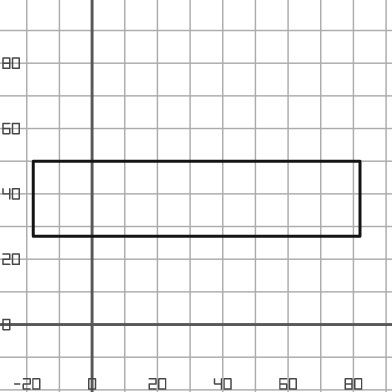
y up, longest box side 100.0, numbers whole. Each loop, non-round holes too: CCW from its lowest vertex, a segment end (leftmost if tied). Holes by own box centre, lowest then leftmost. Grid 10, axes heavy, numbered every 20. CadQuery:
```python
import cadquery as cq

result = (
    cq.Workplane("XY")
    .moveTo(-18.0, 27.0)
    .lineTo(82.0, 27.0)
    .lineTo(82.0, 50.0)
    .lineTo(-18.0, 50.0)
    .close()
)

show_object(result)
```